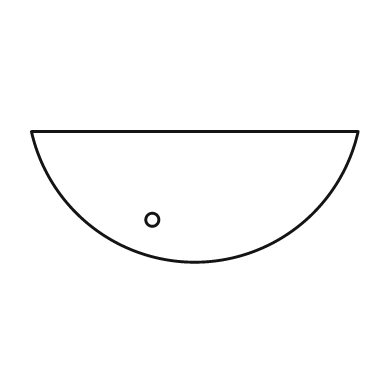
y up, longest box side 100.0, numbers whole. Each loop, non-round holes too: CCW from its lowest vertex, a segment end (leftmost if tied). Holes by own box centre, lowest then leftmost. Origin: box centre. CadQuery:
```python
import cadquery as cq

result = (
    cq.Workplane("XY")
    .moveTo(-50.0, 20.0)
    .threePointArc((0.0, -20.0), (50.0, 20.0))
    .close()
    .moveTo(-13.0, -7.0)
    .circle(2.0)
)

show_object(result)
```